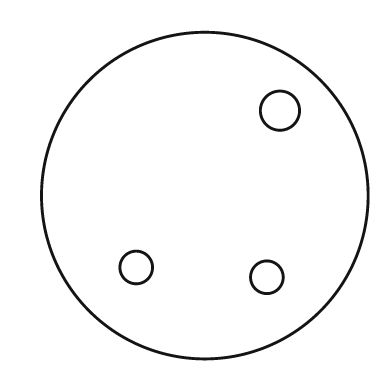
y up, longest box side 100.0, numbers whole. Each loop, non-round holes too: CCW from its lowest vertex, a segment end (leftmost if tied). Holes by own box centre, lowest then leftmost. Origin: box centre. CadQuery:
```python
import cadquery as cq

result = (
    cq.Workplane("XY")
    .moveTo(0.0, 0.0)
    .circle(50.0)
    .moveTo(19.0, -25.0)
    .circle(5.0)
    .moveTo(-21.0, -22.0)
    .circle(5.0)
    .moveTo(23.0, 26.0)
    .circle(6.0)
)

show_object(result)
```